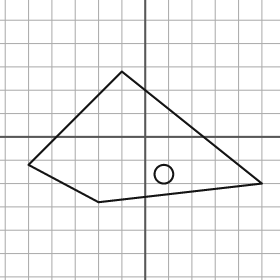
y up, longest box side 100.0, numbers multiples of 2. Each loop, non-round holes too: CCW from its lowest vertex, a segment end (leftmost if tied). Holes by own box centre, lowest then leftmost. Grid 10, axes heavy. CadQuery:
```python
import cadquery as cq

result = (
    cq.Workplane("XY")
    .moveTo(-20.0, -28.0)
    .lineTo(50.0, -20.0)
    .lineTo(-10.0, 28.0)
    .lineTo(-50.0, -12.0)
    .close()
    .moveTo(8.0, -16.0)
    .circle(4.0)
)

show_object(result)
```